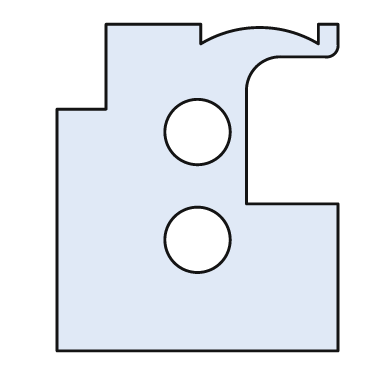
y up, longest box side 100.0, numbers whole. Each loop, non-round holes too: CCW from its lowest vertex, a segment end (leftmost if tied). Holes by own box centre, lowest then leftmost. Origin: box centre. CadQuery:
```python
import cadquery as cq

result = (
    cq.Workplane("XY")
    .moveTo(-43.0, -50.0)
    .lineTo(43.0, -50.0)
    .lineTo(43.0, -5.0)
    .lineTo(15.0, -5.0)
    .lineTo(15.0, 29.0)
    .threePointArc((18.0, 37.0), (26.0, 40.0))
    .lineTo(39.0, 40.0)
    .threePointArc((42.0, 41.0), (43.0, 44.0))
    .lineTo(43.0, 50.0)
    .lineTo(37.0, 50.0)
    .lineTo(37.0, 44.0)
    .threePointArc((19.0, 49.0), (1.0, 44.0))
    .lineTo(1.0, 50.0)
    .lineTo(-28.0, 50.0)
    .lineTo(-28.0, 24.0)
    .lineTo(-43.0, 24.0)
    .close()
    .moveTo(0.0, -16.0)
    .circle(10.0)
    .moveTo(0.0, 17.0)
    .circle(10.0)
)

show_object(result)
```